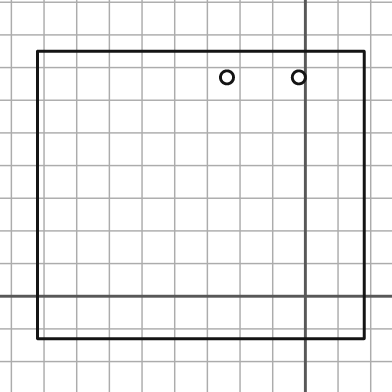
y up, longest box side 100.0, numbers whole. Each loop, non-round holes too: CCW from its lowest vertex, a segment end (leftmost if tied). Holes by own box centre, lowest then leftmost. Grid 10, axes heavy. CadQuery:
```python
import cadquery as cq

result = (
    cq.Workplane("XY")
    .moveTo(-82.0, -13.0)
    .lineTo(18.0, -13.0)
    .lineTo(18.0, 75.0)
    .lineTo(-82.0, 75.0)
    .close()
    .moveTo(-24.0, 67.0)
    .circle(2.0)
    .moveTo(-2.0, 67.0)
    .circle(2.0)
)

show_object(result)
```